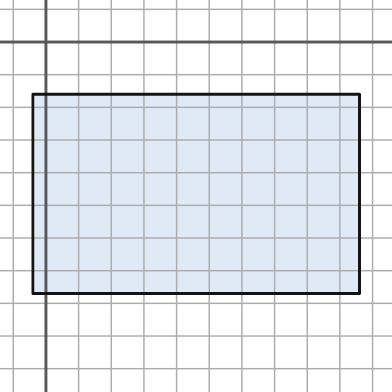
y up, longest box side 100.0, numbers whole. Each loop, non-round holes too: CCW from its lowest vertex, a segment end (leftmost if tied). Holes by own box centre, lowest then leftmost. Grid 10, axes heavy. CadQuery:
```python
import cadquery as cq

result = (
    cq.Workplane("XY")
    .moveTo(-4.0, -77.0)
    .lineTo(96.0, -77.0)
    .lineTo(96.0, -16.0)
    .lineTo(-4.0, -16.0)
    .close()
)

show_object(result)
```